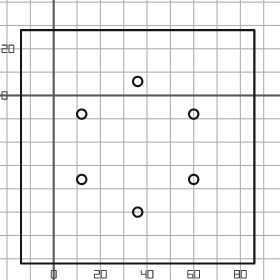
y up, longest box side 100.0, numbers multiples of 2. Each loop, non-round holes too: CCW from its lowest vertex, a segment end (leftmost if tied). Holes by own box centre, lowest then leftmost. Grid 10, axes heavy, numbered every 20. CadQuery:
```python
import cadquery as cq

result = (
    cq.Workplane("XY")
    .moveTo(-14.0, -72.0)
    .lineTo(86.0, -72.0)
    .lineTo(86.0, 28.0)
    .lineTo(-14.0, 28.0)
    .close()
    .moveTo(36.0, -50.0)
    .circle(2.0)
    .moveTo(12.0, -36.0)
    .circle(2.0)
    .moveTo(60.0, -36.0)
    .circle(2.0)
    .moveTo(12.0, -8.0)
    .circle(2.0)
    .moveTo(60.0, -8.0)
    .circle(2.0)
    .moveTo(36.0, 6.0)
    .circle(2.0)
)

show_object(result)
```